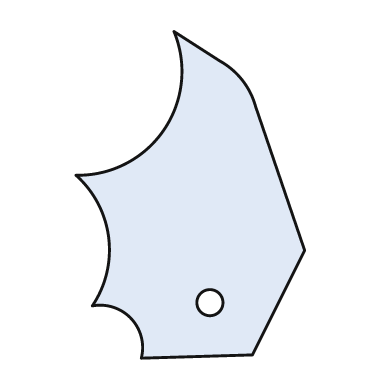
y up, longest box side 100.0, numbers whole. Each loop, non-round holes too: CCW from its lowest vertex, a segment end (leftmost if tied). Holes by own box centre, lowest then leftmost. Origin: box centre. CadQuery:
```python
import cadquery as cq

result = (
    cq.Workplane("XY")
    .moveTo(-15.0, -50.0)
    .lineTo(19.0, -49.0)
    .lineTo(35.0, -17.0)
    .lineTo(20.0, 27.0)
    .threePointArc((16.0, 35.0), (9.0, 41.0))
    .lineTo(-5.0, 50.0)
    .threePointArc((-8.0, 20.0), (-35.0, 6.0))
    .threePointArc((-25.0, -13.0), (-30.0, -34.0))
    .threePointArc((-18.0, -38.0), (-15.0, -50.0))
    .close()
    .moveTo(6.0, -33.0)
    .circle(4.0)
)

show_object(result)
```